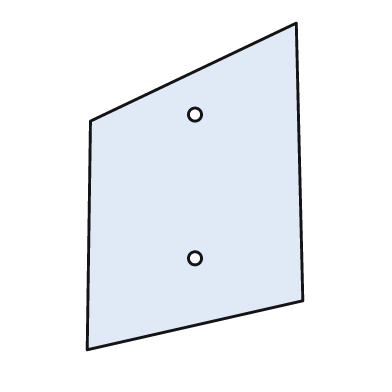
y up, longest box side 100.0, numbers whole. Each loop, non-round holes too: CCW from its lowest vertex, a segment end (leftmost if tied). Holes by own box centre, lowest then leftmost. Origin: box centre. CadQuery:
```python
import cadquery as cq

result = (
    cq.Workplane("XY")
    .moveTo(-33.0, -50.0)
    .lineTo(33.0, -35.0)
    .lineTo(31.0, 50.0)
    .lineTo(-32.0, 20.0)
    .close()
    .moveTo(0.0, -22.0)
    .circle(2.0)
    .moveTo(0.0, 22.0)
    .circle(2.0)
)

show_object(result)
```